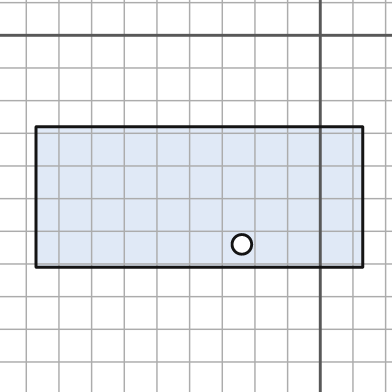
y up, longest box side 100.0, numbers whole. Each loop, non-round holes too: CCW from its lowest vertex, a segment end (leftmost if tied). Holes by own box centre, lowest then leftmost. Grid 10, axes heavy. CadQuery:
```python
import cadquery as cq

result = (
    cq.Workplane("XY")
    .moveTo(-87.0, -71.0)
    .lineTo(13.0, -71.0)
    .lineTo(13.0, -28.0)
    .lineTo(-87.0, -28.0)
    .close()
    .moveTo(-24.0, -64.0)
    .circle(3.0)
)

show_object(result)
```